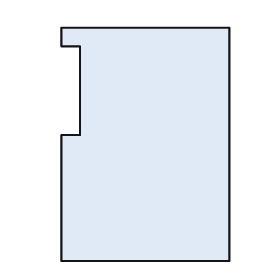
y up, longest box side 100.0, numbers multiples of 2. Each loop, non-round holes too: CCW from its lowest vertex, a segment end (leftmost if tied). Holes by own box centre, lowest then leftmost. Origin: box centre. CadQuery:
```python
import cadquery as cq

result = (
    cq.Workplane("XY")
    .moveTo(-36.0, -50.0)
    .lineTo(36.0, -50.0)
    .lineTo(36.0, 50.0)
    .lineTo(-36.0, 50.0)
    .lineTo(-36.0, 42.0)
    .lineTo(-28.0, 42.0)
    .lineTo(-28.0, 4.0)
    .lineTo(-36.0, 4.0)
    .close()
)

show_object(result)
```